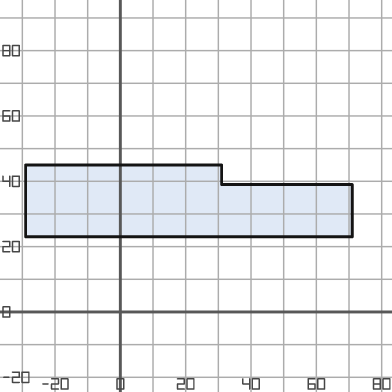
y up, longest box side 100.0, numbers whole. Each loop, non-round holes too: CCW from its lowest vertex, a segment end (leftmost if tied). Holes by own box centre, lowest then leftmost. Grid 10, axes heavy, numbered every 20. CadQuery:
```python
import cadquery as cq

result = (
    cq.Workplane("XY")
    .moveTo(-29.0, 23.0)
    .lineTo(71.0, 23.0)
    .lineTo(71.0, 39.0)
    .lineTo(31.0, 39.0)
    .lineTo(31.0, 45.0)
    .lineTo(-29.0, 45.0)
    .close()
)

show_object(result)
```